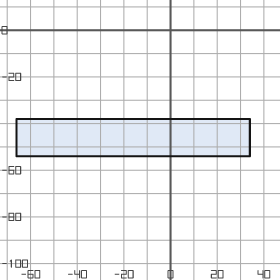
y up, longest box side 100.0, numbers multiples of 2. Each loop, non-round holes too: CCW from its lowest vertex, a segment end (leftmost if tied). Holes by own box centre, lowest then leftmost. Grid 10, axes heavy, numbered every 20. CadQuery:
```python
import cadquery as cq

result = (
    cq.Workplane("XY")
    .moveTo(-66.0, -54.0)
    .lineTo(34.0, -54.0)
    .lineTo(34.0, -38.0)
    .lineTo(-66.0, -38.0)
    .close()
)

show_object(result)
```